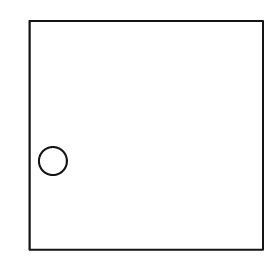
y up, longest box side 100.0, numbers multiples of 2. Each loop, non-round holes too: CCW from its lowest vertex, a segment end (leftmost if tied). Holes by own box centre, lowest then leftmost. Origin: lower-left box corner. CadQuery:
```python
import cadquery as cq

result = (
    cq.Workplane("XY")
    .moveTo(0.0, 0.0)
    .lineTo(100.0, 0.0)
    .lineTo(100.0, 98.0)
    .lineTo(0.0, 98.0)
    .close()
    .moveTo(10.0, 38.0)
    .circle(6.0)
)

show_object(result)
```